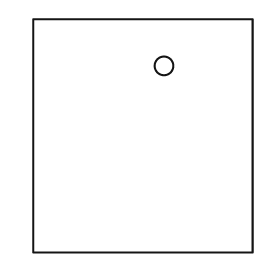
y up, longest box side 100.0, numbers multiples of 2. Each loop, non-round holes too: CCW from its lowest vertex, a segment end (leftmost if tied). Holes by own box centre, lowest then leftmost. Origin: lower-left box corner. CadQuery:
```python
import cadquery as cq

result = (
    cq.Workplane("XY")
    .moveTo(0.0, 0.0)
    .lineTo(94.0, 0.0)
    .lineTo(94.0, 100.0)
    .lineTo(0.0, 100.0)
    .close()
    .moveTo(56.0, 80.0)
    .circle(4.0)
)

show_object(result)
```